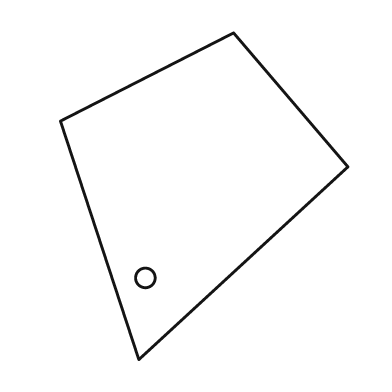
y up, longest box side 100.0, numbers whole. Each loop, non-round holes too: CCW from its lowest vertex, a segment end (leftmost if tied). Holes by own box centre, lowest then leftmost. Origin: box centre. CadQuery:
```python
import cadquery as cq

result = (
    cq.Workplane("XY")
    .moveTo(-20.0, -50.0)
    .lineTo(44.0, 9.0)
    .lineTo(9.0, 50.0)
    .lineTo(-44.0, 23.0)
    .close()
    .moveTo(-18.0, -25.0)
    .circle(3.0)
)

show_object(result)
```